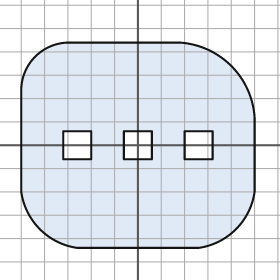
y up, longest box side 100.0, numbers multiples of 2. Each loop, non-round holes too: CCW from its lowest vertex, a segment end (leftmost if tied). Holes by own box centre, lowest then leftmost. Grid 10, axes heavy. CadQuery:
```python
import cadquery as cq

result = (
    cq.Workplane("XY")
    .moveTo(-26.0, -44.0)
    .lineTo(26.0, -44.0)
    .threePointArc((42.0, -36.0), (50.0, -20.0))
    .lineTo(50.0, 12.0)
    .threePointArc((40.0, 34.0), (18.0, 44.0))
    .lineTo(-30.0, 44.0)
    .threePointArc((-44.0, 38.0), (-50.0, 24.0))
    .lineTo(-50.0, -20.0)
    .threePointArc((-42.0, -36.0), (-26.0, -44.0))
    .close()
    .moveTo(-32.0, -6.0)
    .lineTo(-20.0, -6.0)
    .lineTo(-20.0, 6.0)
    .lineTo(-32.0, 6.0)
    .close()
    .moveTo(-6.0, -6.0)
    .lineTo(6.0, -6.0)
    .lineTo(6.0, 6.0)
    .lineTo(-6.0, 6.0)
    .close()
    .moveTo(20.0, -6.0)
    .lineTo(32.0, -6.0)
    .lineTo(32.0, 6.0)
    .lineTo(20.0, 6.0)
    .close()
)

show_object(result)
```